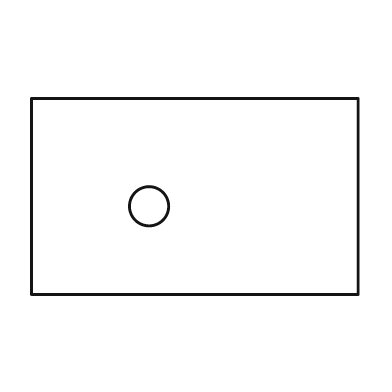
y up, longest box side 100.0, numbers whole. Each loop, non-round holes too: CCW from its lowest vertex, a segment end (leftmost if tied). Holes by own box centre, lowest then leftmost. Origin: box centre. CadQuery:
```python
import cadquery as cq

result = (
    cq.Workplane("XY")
    .moveTo(-50.0, -30.0)
    .lineTo(50.0, -30.0)
    .lineTo(50.0, 30.0)
    .lineTo(-50.0, 30.0)
    .close()
    .moveTo(-14.0, -3.0)
    .circle(6.0)
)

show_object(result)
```